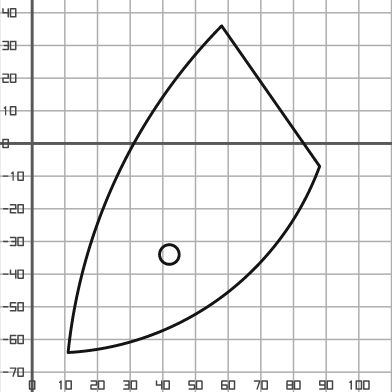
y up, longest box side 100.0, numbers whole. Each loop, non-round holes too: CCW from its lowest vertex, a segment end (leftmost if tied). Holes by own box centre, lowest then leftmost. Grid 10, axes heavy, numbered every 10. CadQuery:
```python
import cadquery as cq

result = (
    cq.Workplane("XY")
    .moveTo(11.0, -64.0)
    .threePointArc((58.0, -47.0), (88.0, -7.0))
    .lineTo(58.0, 36.0)
    .threePointArc((26.0, -10.0), (11.0, -64.0))
    .close()
    .moveTo(42.0, -34.0)
    .circle(3.0)
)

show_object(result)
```